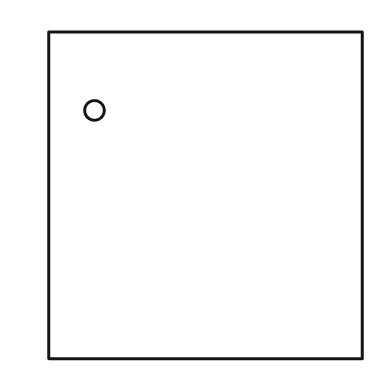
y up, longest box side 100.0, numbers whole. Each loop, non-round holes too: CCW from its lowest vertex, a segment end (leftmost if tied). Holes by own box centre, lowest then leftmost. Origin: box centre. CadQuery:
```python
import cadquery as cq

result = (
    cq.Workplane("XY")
    .moveTo(-48.0, -50.0)
    .lineTo(48.0, -50.0)
    .lineTo(48.0, 50.0)
    .lineTo(-48.0, 50.0)
    .close()
    .moveTo(-34.0, 26.0)
    .circle(3.0)
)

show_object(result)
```